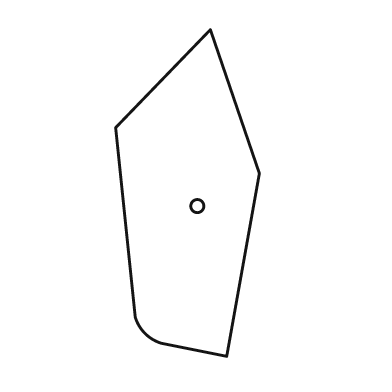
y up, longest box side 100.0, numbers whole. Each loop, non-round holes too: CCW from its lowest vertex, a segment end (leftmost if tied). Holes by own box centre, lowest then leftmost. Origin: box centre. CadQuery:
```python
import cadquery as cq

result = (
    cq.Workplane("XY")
    .moveTo(12.0, -50.0)
    .lineTo(22.0, 6.0)
    .lineTo(7.0, 50.0)
    .lineTo(-22.0, 20.0)
    .lineTo(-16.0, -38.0)
    .threePointArc((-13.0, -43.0), (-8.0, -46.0))
    .close()
    .moveTo(3.0, -4.0)
    .circle(2.0)
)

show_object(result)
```